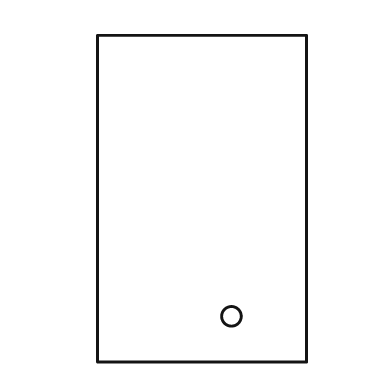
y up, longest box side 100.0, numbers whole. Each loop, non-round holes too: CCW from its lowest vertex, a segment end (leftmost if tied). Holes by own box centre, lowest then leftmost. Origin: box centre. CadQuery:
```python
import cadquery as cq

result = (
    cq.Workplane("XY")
    .moveTo(-32.0, -50.0)
    .lineTo(32.0, -50.0)
    .lineTo(32.0, 50.0)
    .lineTo(-32.0, 50.0)
    .close()
    .moveTo(9.0, -36.0)
    .circle(3.0)
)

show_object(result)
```